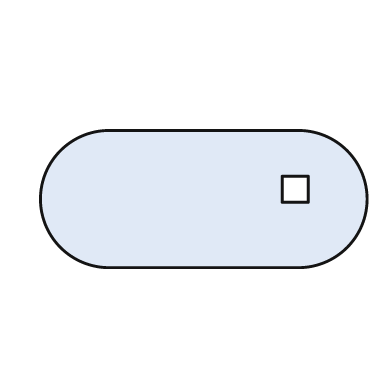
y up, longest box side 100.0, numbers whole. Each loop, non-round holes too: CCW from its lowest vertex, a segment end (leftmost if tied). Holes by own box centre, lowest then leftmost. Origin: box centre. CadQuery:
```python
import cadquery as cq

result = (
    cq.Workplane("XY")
    .moveTo(-29.0, -21.0)
    .lineTo(29.0, -21.0)
    .threePointArc((50.0, 0.0), (29.0, 21.0))
    .lineTo(-29.0, 21.0)
    .threePointArc((-50.0, 0.0), (-29.0, -21.0))
    .close()
    .moveTo(24.0, -1.0)
    .lineTo(32.0, -1.0)
    .lineTo(32.0, 7.0)
    .lineTo(24.0, 7.0)
    .close()
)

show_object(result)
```